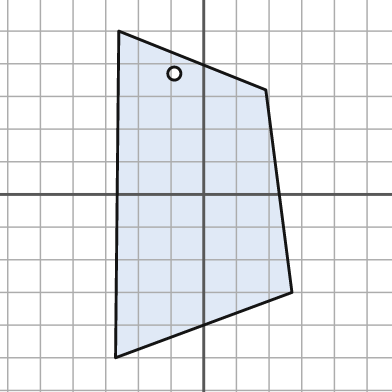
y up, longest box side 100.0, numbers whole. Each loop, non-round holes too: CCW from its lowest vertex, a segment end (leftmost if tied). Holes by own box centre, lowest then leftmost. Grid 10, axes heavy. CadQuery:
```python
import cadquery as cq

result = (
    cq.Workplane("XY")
    .moveTo(-27.0, -50.0)
    .lineTo(27.0, -30.0)
    .lineTo(19.0, 32.0)
    .lineTo(-26.0, 50.0)
    .close()
    .moveTo(-9.0, 37.0)
    .circle(2.0)
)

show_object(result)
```